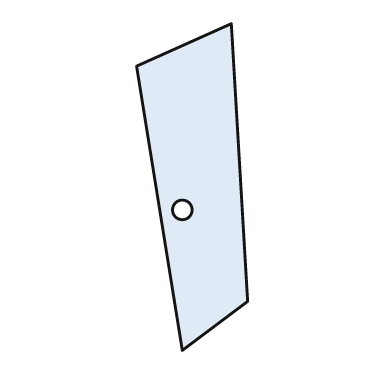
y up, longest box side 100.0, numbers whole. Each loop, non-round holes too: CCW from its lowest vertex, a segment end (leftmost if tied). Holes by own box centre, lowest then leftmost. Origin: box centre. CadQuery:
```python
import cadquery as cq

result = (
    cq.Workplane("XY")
    .moveTo(-3.0, -50.0)
    .lineTo(17.0, -35.0)
    .lineTo(12.0, 50.0)
    .lineTo(-17.0, 37.0)
    .close()
    .moveTo(-3.0, -7.0)
    .circle(3.0)
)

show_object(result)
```